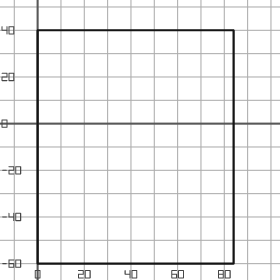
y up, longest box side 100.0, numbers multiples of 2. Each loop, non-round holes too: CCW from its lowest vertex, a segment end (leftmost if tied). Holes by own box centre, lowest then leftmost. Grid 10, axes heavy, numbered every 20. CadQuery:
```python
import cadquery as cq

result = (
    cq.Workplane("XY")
    .moveTo(0.0, -60.0)
    .lineTo(84.0, -60.0)
    .lineTo(84.0, 40.0)
    .lineTo(0.0, 40.0)
    .close()
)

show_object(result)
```